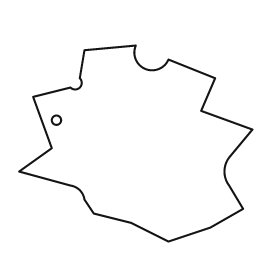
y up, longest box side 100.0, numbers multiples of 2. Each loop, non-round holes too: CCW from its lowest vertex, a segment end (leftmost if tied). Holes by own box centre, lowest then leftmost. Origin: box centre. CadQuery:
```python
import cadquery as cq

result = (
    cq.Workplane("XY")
    .moveTo(14.0, -42.0)
    .lineTo(32.0, -36.0)
    .lineTo(46.0, -28.0)
    .lineTo(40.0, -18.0)
    .threePointArc((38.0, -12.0), (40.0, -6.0))
    .lineTo(50.0, 6.0)
    .lineTo(28.0, 14.0)
    .lineTo(34.0, 28.0)
    .lineTo(14.0, 36.0)
    .threePointArc((4.0, 32.0), (0.0, 42.0))
    .lineTo(-22.0, 40.0)
    .lineTo(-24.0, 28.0)
    .threePointArc((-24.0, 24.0), (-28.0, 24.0))
    .lineTo(-44.0, 20.0)
    .lineTo(-36.0, -2.0)
    .lineTo(-50.0, -12.0)
    .lineTo(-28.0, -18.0)
    .threePointArc((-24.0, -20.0), (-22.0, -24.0))
    .lineTo(-18.0, -30.0)
    .lineTo(-2.0, -34.0)
    .close()
    .moveTo(-34.0, 10.0)
    .circle(2.0)
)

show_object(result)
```